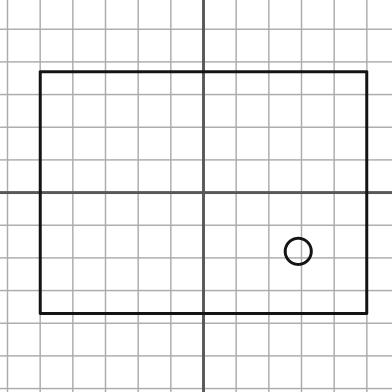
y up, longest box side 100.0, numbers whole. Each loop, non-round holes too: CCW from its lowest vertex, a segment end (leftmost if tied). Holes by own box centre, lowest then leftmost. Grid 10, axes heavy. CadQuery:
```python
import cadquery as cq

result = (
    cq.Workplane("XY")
    .moveTo(-50.0, -37.0)
    .lineTo(50.0, -37.0)
    .lineTo(50.0, 37.0)
    .lineTo(-50.0, 37.0)
    .close()
    .moveTo(29.0, -18.0)
    .circle(4.0)
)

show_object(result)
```